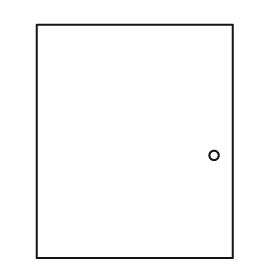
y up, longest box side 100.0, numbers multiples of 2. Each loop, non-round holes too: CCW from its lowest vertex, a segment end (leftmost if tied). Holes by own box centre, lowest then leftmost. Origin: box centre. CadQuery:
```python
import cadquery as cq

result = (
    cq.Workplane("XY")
    .moveTo(-42.0, -50.0)
    .lineTo(42.0, -50.0)
    .lineTo(42.0, 50.0)
    .lineTo(-42.0, 50.0)
    .close()
    .moveTo(34.0, -6.0)
    .circle(2.0)
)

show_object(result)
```